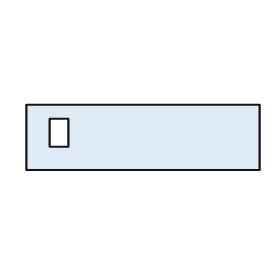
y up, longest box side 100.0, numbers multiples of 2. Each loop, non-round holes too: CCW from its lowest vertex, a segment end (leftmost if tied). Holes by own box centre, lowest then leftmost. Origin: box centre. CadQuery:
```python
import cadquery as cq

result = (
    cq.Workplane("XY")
    .moveTo(-50.0, -14.0)
    .lineTo(50.0, -14.0)
    .lineTo(50.0, 14.0)
    .lineTo(-50.0, 14.0)
    .close()
    .moveTo(-40.0, -4.0)
    .lineTo(-32.0, -4.0)
    .lineTo(-32.0, 8.0)
    .lineTo(-40.0, 8.0)
    .close()
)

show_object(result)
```